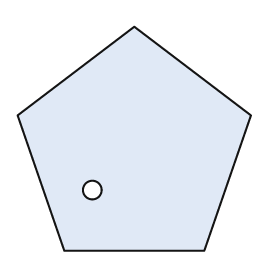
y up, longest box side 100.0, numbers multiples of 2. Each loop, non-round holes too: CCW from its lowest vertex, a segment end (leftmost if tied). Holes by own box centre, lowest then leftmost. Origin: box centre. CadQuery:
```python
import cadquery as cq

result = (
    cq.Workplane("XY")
    .moveTo(-30.0, -48.0)
    .lineTo(30.0, -48.0)
    .lineTo(50.0, 10.0)
    .lineTo(0.0, 48.0)
    .lineTo(-50.0, 10.0)
    .close()
    .moveTo(-18.0, -22.0)
    .circle(4.0)
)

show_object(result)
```